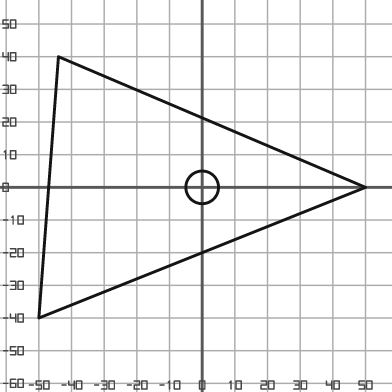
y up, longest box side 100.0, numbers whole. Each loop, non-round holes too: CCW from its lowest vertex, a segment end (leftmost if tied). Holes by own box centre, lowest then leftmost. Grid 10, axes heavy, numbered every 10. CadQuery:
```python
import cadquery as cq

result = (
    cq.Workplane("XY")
    .moveTo(-50.0, -40.0)
    .lineTo(50.0, 0.0)
    .lineTo(-44.0, 40.0)
    .close()
    .moveTo(0.0, 0.0)
    .circle(5.0)
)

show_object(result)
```